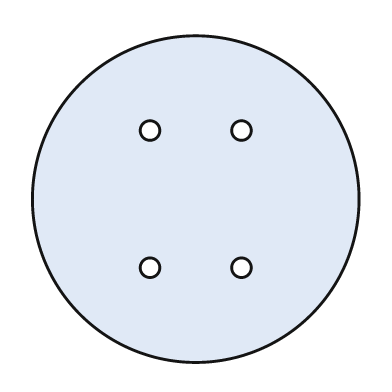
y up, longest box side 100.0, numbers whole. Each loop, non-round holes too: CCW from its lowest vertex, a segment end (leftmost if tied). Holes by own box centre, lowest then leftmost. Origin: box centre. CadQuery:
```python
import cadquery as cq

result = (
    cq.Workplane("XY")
    .moveTo(0.0, 0.0)
    .circle(50.0)
    .moveTo(-14.0, -21.0)
    .circle(3.0)
    .moveTo(14.0, -21.0)
    .circle(3.0)
    .moveTo(-14.0, 21.0)
    .circle(3.0)
    .moveTo(14.0, 21.0)
    .circle(3.0)
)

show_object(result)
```